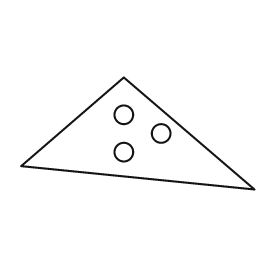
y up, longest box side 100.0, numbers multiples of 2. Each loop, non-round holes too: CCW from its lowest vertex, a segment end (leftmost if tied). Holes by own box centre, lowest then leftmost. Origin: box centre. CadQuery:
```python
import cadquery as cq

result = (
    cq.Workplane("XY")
    .moveTo(50.0, -24.0)
    .lineTo(-6.0, 24.0)
    .lineTo(-50.0, -14.0)
    .close()
    .moveTo(-6.0, -8.0)
    .circle(4.0)
    .moveTo(10.0, 0.0)
    .circle(4.0)
    .moveTo(-6.0, 8.0)
    .circle(4.0)
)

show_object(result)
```